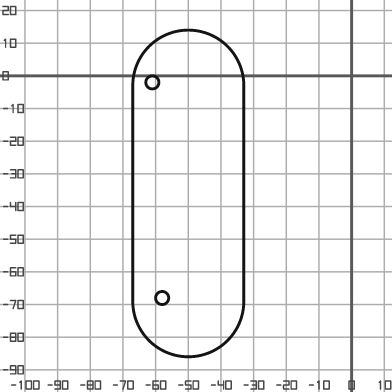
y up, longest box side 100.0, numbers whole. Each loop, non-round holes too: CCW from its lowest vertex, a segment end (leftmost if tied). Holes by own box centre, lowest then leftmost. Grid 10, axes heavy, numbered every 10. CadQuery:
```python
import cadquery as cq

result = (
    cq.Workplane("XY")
    .moveTo(-67.0, -69.0)
    .threePointArc((-50.0, -86.0), (-33.0, -69.0))
    .lineTo(-33.0, -3.0)
    .threePointArc((-50.0, 14.0), (-67.0, -3.0))
    .close()
    .moveTo(-58.0, -68.0)
    .circle(2.0)
    .moveTo(-61.0, -2.0)
    .circle(2.0)
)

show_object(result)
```